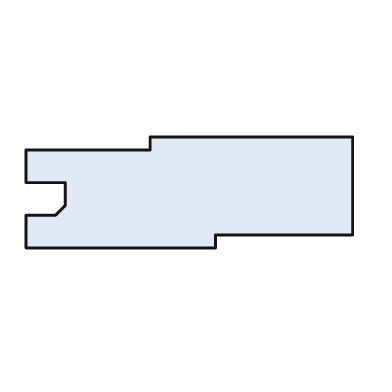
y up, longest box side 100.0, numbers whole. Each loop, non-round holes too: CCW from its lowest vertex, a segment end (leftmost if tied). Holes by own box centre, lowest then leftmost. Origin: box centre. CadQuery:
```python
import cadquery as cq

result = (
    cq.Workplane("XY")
    .moveTo(-50.0, -17.0)
    .lineTo(8.0, -17.0)
    .lineTo(8.0, -13.0)
    .lineTo(50.0, -13.0)
    .lineTo(50.0, 17.0)
    .lineTo(-12.0, 17.0)
    .lineTo(-12.0, 13.0)
    .lineTo(-50.0, 13.0)
    .lineTo(-50.0, 3.0)
    .lineTo(-38.0, 3.0)
    .lineTo(-38.0, -4.0)
    .lineTo(-41.0, -7.0)
    .lineTo(-50.0, -7.0)
    .close()
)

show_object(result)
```